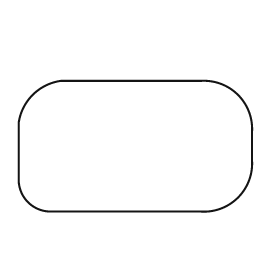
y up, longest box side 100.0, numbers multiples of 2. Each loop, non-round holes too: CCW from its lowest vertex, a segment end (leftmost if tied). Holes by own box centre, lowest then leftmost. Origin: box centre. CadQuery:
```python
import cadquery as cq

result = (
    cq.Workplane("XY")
    .moveTo(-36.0, -28.0)
    .lineTo(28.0, -28.0)
    .threePointArc((44.0, -22.0), (50.0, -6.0))
    .lineTo(50.0, 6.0)
    .threePointArc((44.0, 22.0), (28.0, 28.0))
    .lineTo(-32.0, 28.0)
    .threePointArc((-44.0, 22.0), (-50.0, 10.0))
    .lineTo(-50.0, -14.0)
    .threePointArc((-46.0, -24.0), (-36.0, -28.0))
    .close()
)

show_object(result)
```